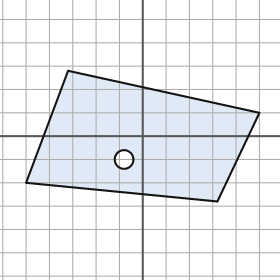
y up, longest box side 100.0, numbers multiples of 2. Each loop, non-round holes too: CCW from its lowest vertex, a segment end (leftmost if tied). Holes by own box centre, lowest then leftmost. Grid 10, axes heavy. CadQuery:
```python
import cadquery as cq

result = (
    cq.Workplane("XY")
    .moveTo(32.0, -28.0)
    .lineTo(50.0, 10.0)
    .lineTo(-32.0, 28.0)
    .lineTo(-50.0, -20.0)
    .close()
    .moveTo(-8.0, -10.0)
    .circle(4.0)
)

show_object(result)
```